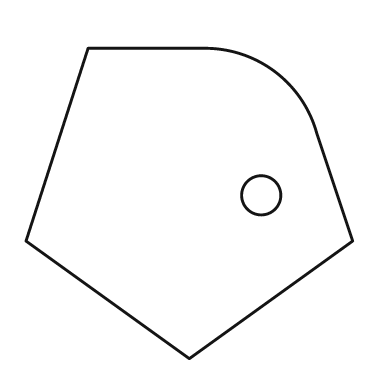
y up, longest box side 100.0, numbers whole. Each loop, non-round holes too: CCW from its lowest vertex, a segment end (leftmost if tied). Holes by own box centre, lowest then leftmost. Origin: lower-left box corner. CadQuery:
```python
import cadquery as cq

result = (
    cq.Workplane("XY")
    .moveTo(50.0, 0.0)
    .lineTo(100.0, 36.0)
    .lineTo(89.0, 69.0)
    .threePointArc((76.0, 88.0), (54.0, 95.0))
    .lineTo(19.0, 95.0)
    .lineTo(0.0, 36.0)
    .close()
    .moveTo(72.0, 50.0)
    .circle(6.0)
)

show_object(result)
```